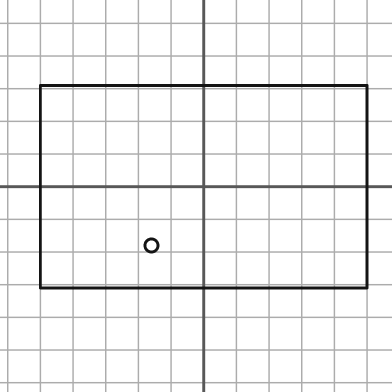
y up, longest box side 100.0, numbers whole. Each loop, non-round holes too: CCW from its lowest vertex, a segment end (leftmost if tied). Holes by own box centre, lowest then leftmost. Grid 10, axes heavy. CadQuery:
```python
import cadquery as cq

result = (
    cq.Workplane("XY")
    .moveTo(-50.0, -31.0)
    .lineTo(50.0, -31.0)
    .lineTo(50.0, 31.0)
    .lineTo(-50.0, 31.0)
    .close()
    .moveTo(-16.0, -18.0)
    .circle(2.0)
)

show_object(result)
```